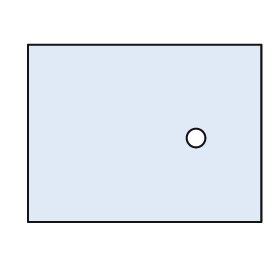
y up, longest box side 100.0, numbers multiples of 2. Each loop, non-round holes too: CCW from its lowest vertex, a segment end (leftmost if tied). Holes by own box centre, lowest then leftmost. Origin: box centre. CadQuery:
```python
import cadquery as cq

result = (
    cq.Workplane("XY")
    .moveTo(-50.0, -38.0)
    .lineTo(50.0, -38.0)
    .lineTo(50.0, 38.0)
    .lineTo(-50.0, 38.0)
    .close()
    .moveTo(22.0, -2.0)
    .circle(4.0)
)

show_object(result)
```